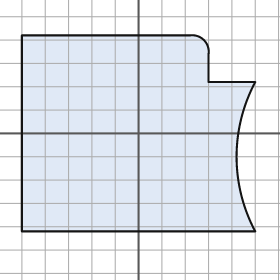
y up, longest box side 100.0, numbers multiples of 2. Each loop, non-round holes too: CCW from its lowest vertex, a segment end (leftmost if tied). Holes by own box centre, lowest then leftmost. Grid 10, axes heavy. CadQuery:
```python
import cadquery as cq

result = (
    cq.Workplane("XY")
    .moveTo(-50.0, -42.0)
    .lineTo(50.0, -42.0)
    .threePointArc((42.0, -10.0), (50.0, 22.0))
    .lineTo(30.0, 22.0)
    .lineTo(30.0, 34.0)
    .threePointArc((28.0, 40.0), (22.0, 42.0))
    .lineTo(-50.0, 42.0)
    .close()
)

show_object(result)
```